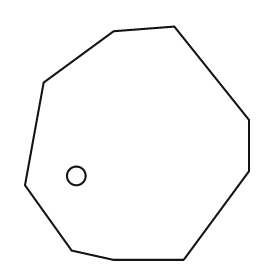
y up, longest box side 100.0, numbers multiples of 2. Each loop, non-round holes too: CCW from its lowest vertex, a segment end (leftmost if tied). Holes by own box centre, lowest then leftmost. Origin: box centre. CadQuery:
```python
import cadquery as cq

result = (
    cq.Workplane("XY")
    .moveTo(-10.0, -50.0)
    .lineTo(20.0, -50.0)
    .lineTo(48.0, -12.0)
    .lineTo(48.0, 10.0)
    .lineTo(16.0, 50.0)
    .lineTo(-10.0, 48.0)
    .lineTo(-40.0, 26.0)
    .lineTo(-48.0, -18.0)
    .lineTo(-28.0, -46.0)
    .close()
    .moveTo(-26.0, -14.0)
    .circle(4.0)
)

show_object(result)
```